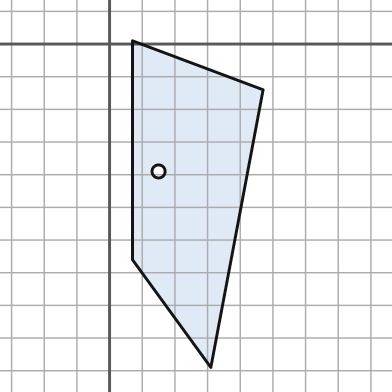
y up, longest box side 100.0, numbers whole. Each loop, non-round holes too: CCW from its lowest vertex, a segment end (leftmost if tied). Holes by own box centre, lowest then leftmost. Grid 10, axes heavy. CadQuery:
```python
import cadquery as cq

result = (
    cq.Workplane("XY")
    .moveTo(31.0, -99.0)
    .lineTo(47.0, -14.0)
    .lineTo(7.0, 1.0)
    .lineTo(7.0, -66.0)
    .close()
    .moveTo(15.0, -39.0)
    .circle(2.0)
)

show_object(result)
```